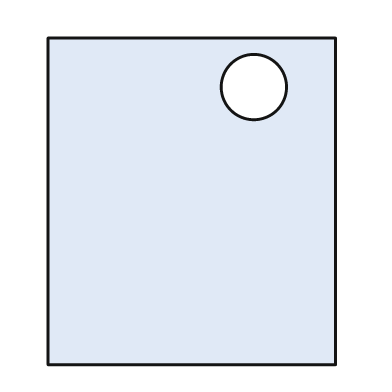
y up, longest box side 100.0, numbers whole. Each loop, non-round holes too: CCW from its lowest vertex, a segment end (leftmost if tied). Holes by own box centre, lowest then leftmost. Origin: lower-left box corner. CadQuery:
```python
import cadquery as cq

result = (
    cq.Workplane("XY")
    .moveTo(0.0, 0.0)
    .lineTo(88.0, 0.0)
    .lineTo(88.0, 100.0)
    .lineTo(0.0, 100.0)
    .close()
    .moveTo(63.0, 85.0)
    .circle(10.0)
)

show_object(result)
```